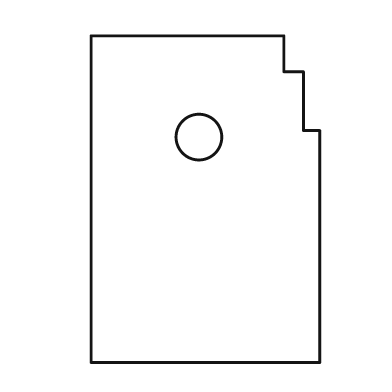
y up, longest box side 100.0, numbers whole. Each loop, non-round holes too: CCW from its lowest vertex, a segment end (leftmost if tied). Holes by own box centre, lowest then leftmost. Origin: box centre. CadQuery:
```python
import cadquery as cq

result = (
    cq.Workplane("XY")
    .moveTo(-35.0, -50.0)
    .lineTo(35.0, -50.0)
    .lineTo(35.0, 21.0)
    .lineTo(30.0, 21.0)
    .lineTo(30.0, 39.0)
    .lineTo(24.0, 39.0)
    .lineTo(24.0, 50.0)
    .lineTo(-35.0, 50.0)
    .close()
    .moveTo(-2.0, 19.0)
    .circle(7.0)
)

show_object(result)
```